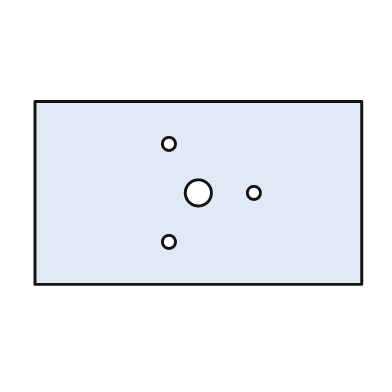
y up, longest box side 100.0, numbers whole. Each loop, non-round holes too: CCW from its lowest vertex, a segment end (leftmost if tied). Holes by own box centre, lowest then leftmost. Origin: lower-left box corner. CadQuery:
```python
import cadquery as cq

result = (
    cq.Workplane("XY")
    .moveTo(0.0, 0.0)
    .lineTo(100.0, 0.0)
    .lineTo(100.0, 56.0)
    .lineTo(0.0, 56.0)
    .close()
    .moveTo(41.0, 13.0)
    .circle(2.0)
    .moveTo(50.0, 28.0)
    .circle(4.0)
    .moveTo(67.0, 28.0)
    .circle(2.0)
    .moveTo(41.0, 43.0)
    .circle(2.0)
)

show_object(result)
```